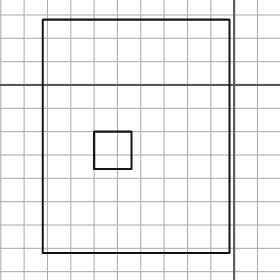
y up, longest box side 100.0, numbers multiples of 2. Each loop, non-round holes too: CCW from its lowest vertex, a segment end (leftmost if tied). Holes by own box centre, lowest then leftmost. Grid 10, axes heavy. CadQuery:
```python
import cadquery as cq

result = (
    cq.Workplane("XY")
    .moveTo(-82.0, -72.0)
    .lineTo(-2.0, -72.0)
    .lineTo(-2.0, 28.0)
    .lineTo(-82.0, 28.0)
    .close()
    .moveTo(-60.0, -36.0)
    .lineTo(-44.0, -36.0)
    .lineTo(-44.0, -20.0)
    .lineTo(-60.0, -20.0)
    .close()
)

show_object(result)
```